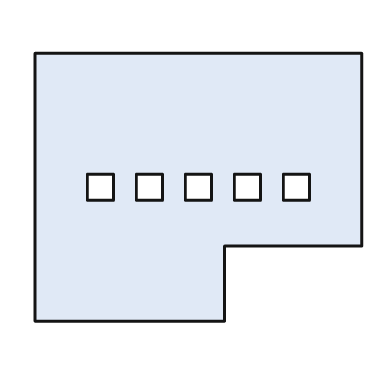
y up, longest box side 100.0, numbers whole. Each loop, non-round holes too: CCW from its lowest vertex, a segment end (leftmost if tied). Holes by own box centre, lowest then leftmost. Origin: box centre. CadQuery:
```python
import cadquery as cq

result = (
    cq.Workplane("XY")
    .moveTo(-50.0, -41.0)
    .lineTo(8.0, -41.0)
    .lineTo(8.0, -18.0)
    .lineTo(50.0, -18.0)
    .lineTo(50.0, 41.0)
    .lineTo(-50.0, 41.0)
    .close()
    .moveTo(-34.0, -4.0)
    .lineTo(-26.0, -4.0)
    .lineTo(-26.0, 4.0)
    .lineTo(-34.0, 4.0)
    .close()
    .moveTo(-19.0, -4.0)
    .lineTo(-11.0, -4.0)
    .lineTo(-11.0, 4.0)
    .lineTo(-19.0, 4.0)
    .close()
    .moveTo(-4.0, -4.0)
    .lineTo(4.0, -4.0)
    .lineTo(4.0, 4.0)
    .lineTo(-4.0, 4.0)
    .close()
    .moveTo(11.0, -4.0)
    .lineTo(19.0, -4.0)
    .lineTo(19.0, 4.0)
    .lineTo(11.0, 4.0)
    .close()
    .moveTo(26.0, -4.0)
    .lineTo(34.0, -4.0)
    .lineTo(34.0, 4.0)
    .lineTo(26.0, 4.0)
    .close()
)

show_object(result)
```